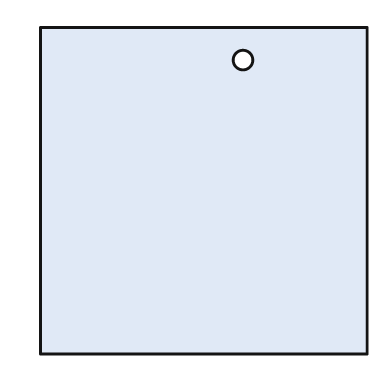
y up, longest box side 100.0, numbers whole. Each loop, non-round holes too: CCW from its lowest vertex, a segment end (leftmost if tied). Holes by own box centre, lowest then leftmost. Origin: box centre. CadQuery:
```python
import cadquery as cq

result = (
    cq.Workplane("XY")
    .moveTo(-50.0, -50.0)
    .lineTo(50.0, -50.0)
    .lineTo(50.0, 50.0)
    .lineTo(-50.0, 50.0)
    .close()
    .moveTo(12.0, 40.0)
    .circle(3.0)
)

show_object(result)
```